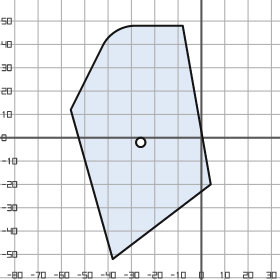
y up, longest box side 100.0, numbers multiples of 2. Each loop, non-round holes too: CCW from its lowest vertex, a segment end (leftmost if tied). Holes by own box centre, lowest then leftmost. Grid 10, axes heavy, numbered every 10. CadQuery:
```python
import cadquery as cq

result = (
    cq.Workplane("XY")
    .moveTo(-38.0, -52.0)
    .lineTo(4.0, -20.0)
    .lineTo(-8.0, 48.0)
    .lineTo(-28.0, 48.0)
    .threePointArc((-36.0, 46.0), (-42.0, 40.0))
    .lineTo(-56.0, 12.0)
    .close()
    .moveTo(-26.0, -2.0)
    .circle(2.0)
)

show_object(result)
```